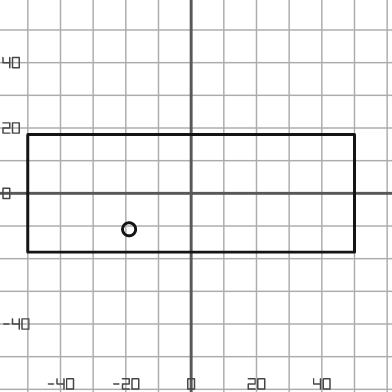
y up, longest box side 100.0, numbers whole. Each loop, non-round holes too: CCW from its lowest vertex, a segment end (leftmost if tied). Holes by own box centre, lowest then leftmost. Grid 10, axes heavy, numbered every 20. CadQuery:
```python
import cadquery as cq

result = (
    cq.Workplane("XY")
    .moveTo(-50.0, -18.0)
    .lineTo(50.0, -18.0)
    .lineTo(50.0, 18.0)
    .lineTo(-50.0, 18.0)
    .close()
    .moveTo(-19.0, -11.0)
    .circle(2.0)
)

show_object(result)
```